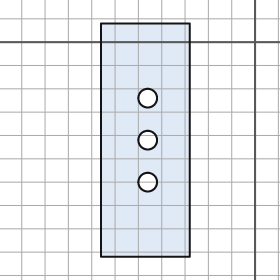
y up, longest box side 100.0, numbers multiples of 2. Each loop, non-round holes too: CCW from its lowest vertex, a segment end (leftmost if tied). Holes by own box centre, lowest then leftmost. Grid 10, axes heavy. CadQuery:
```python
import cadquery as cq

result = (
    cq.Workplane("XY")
    .moveTo(-66.0, -92.0)
    .lineTo(-28.0, -92.0)
    .lineTo(-28.0, 8.0)
    .lineTo(-66.0, 8.0)
    .close()
    .moveTo(-46.0, -60.0)
    .circle(4.0)
    .moveTo(-46.0, -42.0)
    .circle(4.0)
    .moveTo(-46.0, -24.0)
    .circle(4.0)
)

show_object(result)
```